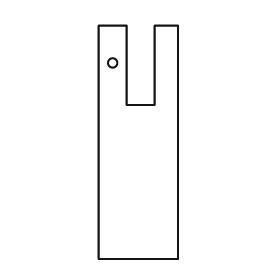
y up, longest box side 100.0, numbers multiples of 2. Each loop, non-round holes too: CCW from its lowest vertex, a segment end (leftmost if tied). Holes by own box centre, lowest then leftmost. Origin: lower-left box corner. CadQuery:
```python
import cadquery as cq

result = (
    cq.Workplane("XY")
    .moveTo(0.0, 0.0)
    .lineTo(34.0, 0.0)
    .lineTo(34.0, 100.0)
    .lineTo(24.0, 100.0)
    .lineTo(24.0, 66.0)
    .lineTo(12.0, 66.0)
    .lineTo(12.0, 100.0)
    .lineTo(0.0, 100.0)
    .close()
    .moveTo(6.0, 84.0)
    .circle(2.0)
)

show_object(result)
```